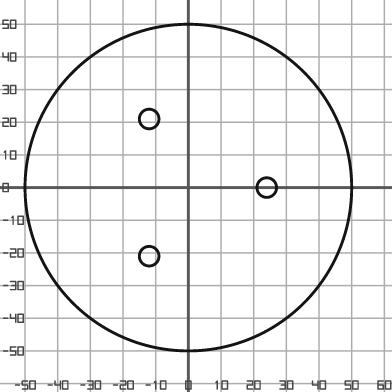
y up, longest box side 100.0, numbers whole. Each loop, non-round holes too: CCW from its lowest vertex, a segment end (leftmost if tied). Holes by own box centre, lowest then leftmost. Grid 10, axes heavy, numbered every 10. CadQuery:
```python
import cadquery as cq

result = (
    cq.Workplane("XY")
    .moveTo(0.0, 0.0)
    .circle(50.0)
    .moveTo(-12.0, -21.0)
    .circle(3.0)
    .moveTo(24.0, 0.0)
    .circle(3.0)
    .moveTo(-12.0, 21.0)
    .circle(3.0)
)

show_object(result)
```